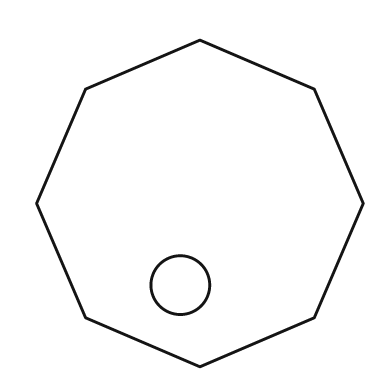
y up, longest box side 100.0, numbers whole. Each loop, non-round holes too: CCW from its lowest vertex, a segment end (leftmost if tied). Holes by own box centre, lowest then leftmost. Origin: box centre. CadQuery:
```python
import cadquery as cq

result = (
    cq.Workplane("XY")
    .moveTo(0.0, -50.0)
    .lineTo(35.0, -35.0)
    .lineTo(50.0, 0.0)
    .lineTo(35.0, 35.0)
    .lineTo(0.0, 50.0)
    .lineTo(-35.0, 35.0)
    .lineTo(-50.0, 0.0)
    .lineTo(-35.0, -35.0)
    .close()
    .moveTo(-6.0, -25.0)
    .circle(9.0)
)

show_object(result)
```